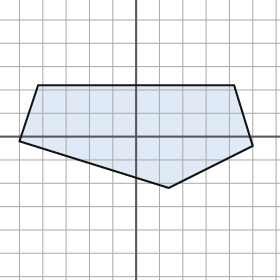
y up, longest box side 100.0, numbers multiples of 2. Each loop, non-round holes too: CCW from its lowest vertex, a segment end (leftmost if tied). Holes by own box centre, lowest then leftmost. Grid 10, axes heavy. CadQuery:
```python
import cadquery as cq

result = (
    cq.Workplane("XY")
    .moveTo(14.0, -22.0)
    .lineTo(50.0, -4.0)
    .lineTo(42.0, 22.0)
    .lineTo(-42.0, 22.0)
    .lineTo(-50.0, -2.0)
    .close()
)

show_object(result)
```